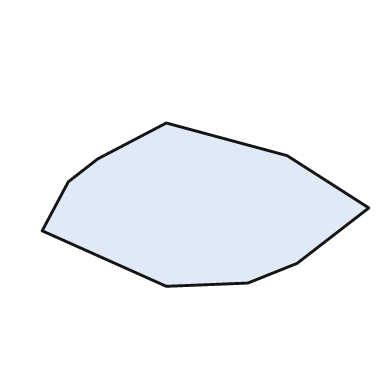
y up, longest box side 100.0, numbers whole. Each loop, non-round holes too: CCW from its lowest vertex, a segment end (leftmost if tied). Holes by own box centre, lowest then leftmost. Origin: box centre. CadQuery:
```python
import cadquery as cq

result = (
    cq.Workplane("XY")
    .moveTo(-12.0, -25.0)
    .lineTo(13.0, -24.0)
    .lineTo(28.0, -18.0)
    .lineTo(50.0, -1.0)
    .lineTo(25.0, 15.0)
    .lineTo(-12.0, 25.0)
    .lineTo(-33.0, 14.0)
    .lineTo(-42.0, 7.0)
    .lineTo(-50.0, -8.0)
    .close()
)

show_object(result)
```